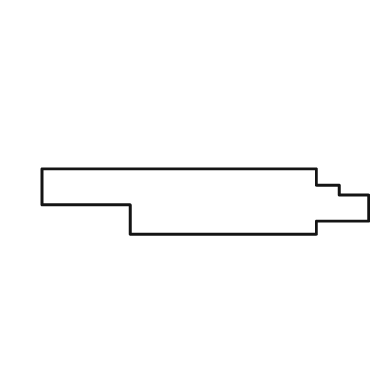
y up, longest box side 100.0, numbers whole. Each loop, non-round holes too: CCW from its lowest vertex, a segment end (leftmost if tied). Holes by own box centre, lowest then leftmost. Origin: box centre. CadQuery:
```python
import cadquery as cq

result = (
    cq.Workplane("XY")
    .moveTo(-23.0, -10.0)
    .lineTo(34.0, -10.0)
    .lineTo(34.0, -6.0)
    .lineTo(50.0, -6.0)
    .lineTo(50.0, 2.0)
    .lineTo(41.0, 2.0)
    .lineTo(41.0, 5.0)
    .lineTo(34.0, 5.0)
    .lineTo(34.0, 10.0)
    .lineTo(-50.0, 10.0)
    .lineTo(-50.0, -1.0)
    .lineTo(-23.0, -1.0)
    .close()
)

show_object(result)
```